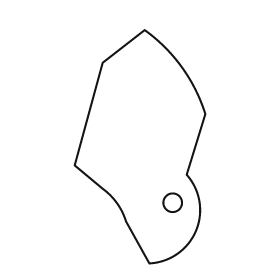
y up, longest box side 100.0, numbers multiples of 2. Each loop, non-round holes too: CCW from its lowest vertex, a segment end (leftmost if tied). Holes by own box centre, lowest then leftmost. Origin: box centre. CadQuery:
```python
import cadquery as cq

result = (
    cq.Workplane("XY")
    .moveTo(4.0, -50.0)
    .threePointArc((24.0, -36.0), (20.0, -12.0))
    .lineTo(28.0, 14.0)
    .threePointArc((18.0, 34.0), (2.0, 50.0))
    .lineTo(-16.0, 36.0)
    .lineTo(-28.0, -8.0)
    .lineTo(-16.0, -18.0)
    .threePointArc((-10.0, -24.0), (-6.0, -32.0))
    .close()
    .moveTo(14.0, -24.0)
    .circle(4.0)
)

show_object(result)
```